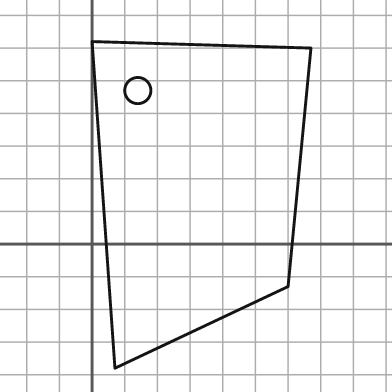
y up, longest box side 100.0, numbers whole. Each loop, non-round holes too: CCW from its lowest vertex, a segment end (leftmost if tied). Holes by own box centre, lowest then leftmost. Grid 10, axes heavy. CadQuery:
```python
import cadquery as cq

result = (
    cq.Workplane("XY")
    .moveTo(7.0, -38.0)
    .lineTo(60.0, -13.0)
    .lineTo(67.0, 60.0)
    .lineTo(0.0, 62.0)
    .close()
    .moveTo(14.0, 47.0)
    .circle(4.0)
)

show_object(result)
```